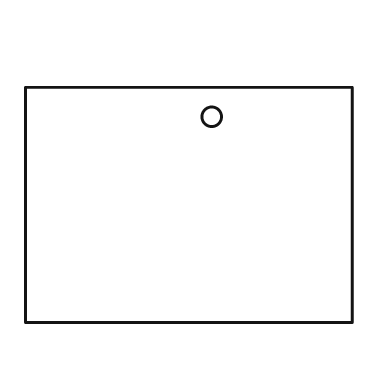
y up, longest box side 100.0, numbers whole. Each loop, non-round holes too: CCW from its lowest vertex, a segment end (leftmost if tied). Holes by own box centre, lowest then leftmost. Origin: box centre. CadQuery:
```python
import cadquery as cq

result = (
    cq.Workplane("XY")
    .moveTo(-50.0, -36.0)
    .lineTo(50.0, -36.0)
    .lineTo(50.0, 36.0)
    .lineTo(-50.0, 36.0)
    .close()
    .moveTo(7.0, 27.0)
    .circle(3.0)
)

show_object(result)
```